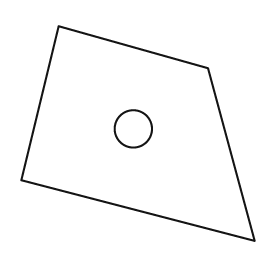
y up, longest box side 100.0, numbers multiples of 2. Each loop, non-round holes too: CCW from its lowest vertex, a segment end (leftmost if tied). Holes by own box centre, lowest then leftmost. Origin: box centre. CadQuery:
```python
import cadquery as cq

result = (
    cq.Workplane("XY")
    .moveTo(50.0, -46.0)
    .lineTo(30.0, 28.0)
    .lineTo(-34.0, 46.0)
    .lineTo(-50.0, -20.0)
    .close()
    .moveTo(-2.0, 2.0)
    .circle(8.0)
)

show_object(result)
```